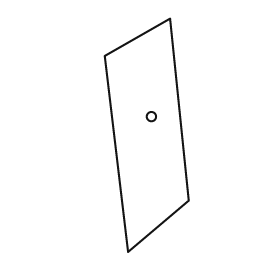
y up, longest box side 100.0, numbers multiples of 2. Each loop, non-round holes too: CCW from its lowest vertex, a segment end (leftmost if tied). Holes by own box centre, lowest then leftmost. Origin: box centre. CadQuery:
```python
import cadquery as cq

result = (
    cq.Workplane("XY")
    .moveTo(-8.0, -50.0)
    .lineTo(18.0, -28.0)
    .lineTo(10.0, 50.0)
    .lineTo(-18.0, 34.0)
    .close()
    .moveTo(2.0, 8.0)
    .circle(2.0)
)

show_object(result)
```